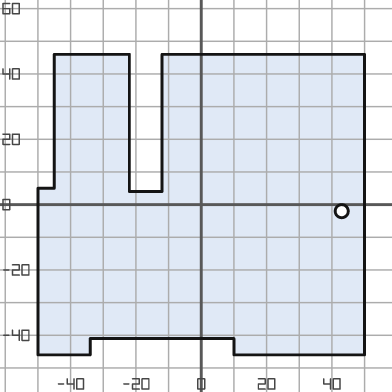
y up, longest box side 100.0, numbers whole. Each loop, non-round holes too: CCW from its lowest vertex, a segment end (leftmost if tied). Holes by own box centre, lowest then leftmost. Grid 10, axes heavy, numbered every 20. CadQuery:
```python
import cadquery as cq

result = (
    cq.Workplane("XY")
    .moveTo(-50.0, -46.0)
    .lineTo(-34.0, -46.0)
    .lineTo(-34.0, -41.0)
    .lineTo(10.0, -41.0)
    .lineTo(10.0, -46.0)
    .lineTo(50.0, -46.0)
    .lineTo(50.0, 46.0)
    .lineTo(-12.0, 46.0)
    .lineTo(-12.0, 4.0)
    .lineTo(-22.0, 4.0)
    .lineTo(-22.0, 46.0)
    .lineTo(-45.0, 46.0)
    .lineTo(-45.0, 5.0)
    .lineTo(-50.0, 5.0)
    .close()
    .moveTo(43.0, -2.0)
    .circle(2.0)
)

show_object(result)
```